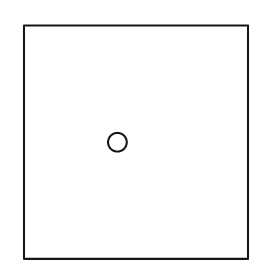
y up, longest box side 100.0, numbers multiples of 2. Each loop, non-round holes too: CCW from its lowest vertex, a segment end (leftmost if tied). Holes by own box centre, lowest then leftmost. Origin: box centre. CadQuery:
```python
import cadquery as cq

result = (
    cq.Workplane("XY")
    .moveTo(-48.0, -50.0)
    .lineTo(48.0, -50.0)
    .lineTo(48.0, 50.0)
    .lineTo(-48.0, 50.0)
    .close()
    .moveTo(-8.0, 0.0)
    .circle(4.0)
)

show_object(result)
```